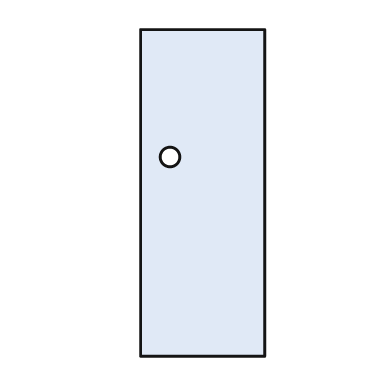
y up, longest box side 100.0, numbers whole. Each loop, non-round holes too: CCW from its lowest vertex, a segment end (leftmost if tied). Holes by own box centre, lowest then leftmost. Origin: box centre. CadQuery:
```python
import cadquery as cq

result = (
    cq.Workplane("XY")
    .moveTo(-19.0, -50.0)
    .lineTo(19.0, -50.0)
    .lineTo(19.0, 50.0)
    .lineTo(-19.0, 50.0)
    .close()
    .moveTo(-10.0, 11.0)
    .circle(3.0)
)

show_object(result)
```